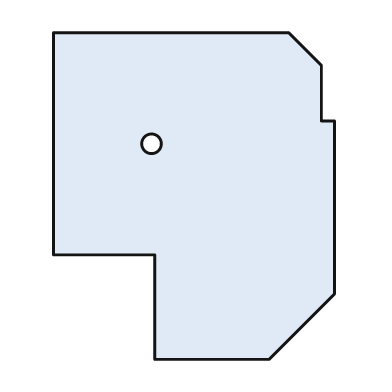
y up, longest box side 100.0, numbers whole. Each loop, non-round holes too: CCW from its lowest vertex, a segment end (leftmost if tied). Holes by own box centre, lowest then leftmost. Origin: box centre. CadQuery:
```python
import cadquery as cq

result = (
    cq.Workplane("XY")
    .moveTo(-12.0, -50.0)
    .lineTo(23.0, -50.0)
    .lineTo(43.0, -30.0)
    .lineTo(43.0, 23.0)
    .lineTo(39.0, 23.0)
    .lineTo(39.0, 40.0)
    .lineTo(29.0, 50.0)
    .lineTo(-43.0, 50.0)
    .lineTo(-43.0, -18.0)
    .lineTo(-12.0, -18.0)
    .close()
    .moveTo(-13.0, 16.0)
    .circle(3.0)
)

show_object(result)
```